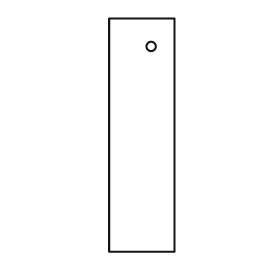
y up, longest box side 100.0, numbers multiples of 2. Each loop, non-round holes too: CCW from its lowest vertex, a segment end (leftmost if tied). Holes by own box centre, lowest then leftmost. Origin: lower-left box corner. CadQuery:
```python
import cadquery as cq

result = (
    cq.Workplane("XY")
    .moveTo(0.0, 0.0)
    .lineTo(28.0, 0.0)
    .lineTo(28.0, 100.0)
    .lineTo(0.0, 100.0)
    .close()
    .moveTo(18.0, 88.0)
    .circle(2.0)
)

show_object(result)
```